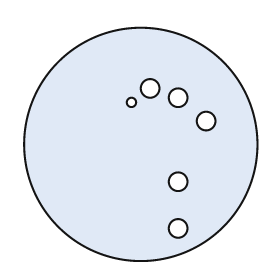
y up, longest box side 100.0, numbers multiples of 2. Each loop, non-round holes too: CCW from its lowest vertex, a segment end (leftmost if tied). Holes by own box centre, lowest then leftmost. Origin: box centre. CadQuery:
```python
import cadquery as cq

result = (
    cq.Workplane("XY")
    .moveTo(0.0, 0.0)
    .circle(50.0)
    .moveTo(16.0, -36.0)
    .circle(4.0)
    .moveTo(16.0, -16.0)
    .circle(4.0)
    .moveTo(28.0, 10.0)
    .circle(4.0)
    .moveTo(-4.0, 18.0)
    .circle(2.0)
    .moveTo(16.0, 20.0)
    .circle(4.0)
    .moveTo(4.0, 24.0)
    .circle(4.0)
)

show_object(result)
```